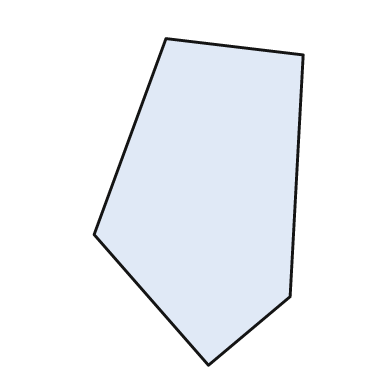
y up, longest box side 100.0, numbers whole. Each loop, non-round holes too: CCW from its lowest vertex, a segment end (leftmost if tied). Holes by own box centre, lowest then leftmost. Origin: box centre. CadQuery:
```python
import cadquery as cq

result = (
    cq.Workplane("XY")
    .moveTo(3.0, -50.0)
    .lineTo(28.0, -29.0)
    .lineTo(32.0, 45.0)
    .lineTo(-10.0, 50.0)
    .lineTo(-32.0, -10.0)
    .close()
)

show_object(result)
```